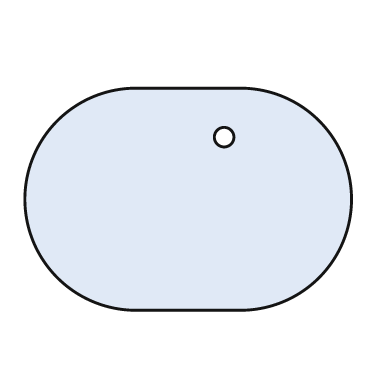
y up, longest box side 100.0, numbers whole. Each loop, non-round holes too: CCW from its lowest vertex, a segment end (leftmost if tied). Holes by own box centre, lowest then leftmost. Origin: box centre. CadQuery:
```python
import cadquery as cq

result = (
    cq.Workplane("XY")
    .moveTo(-16.0, -34.0)
    .lineTo(16.0, -34.0)
    .threePointArc((50.0, 0.0), (16.0, 34.0))
    .lineTo(-16.0, 34.0)
    .threePointArc((-50.0, 0.0), (-16.0, -34.0))
    .close()
    .moveTo(11.0, 19.0)
    .circle(3.0)
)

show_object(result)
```